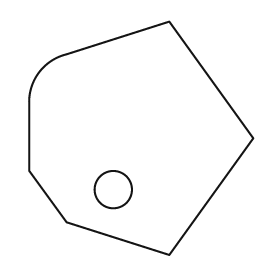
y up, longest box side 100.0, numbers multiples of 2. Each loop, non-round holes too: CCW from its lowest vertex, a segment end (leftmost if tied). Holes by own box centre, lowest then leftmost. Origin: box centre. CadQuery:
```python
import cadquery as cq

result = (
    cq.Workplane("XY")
    .moveTo(12.0, -50.0)
    .lineTo(48.0, 0.0)
    .lineTo(12.0, 50.0)
    .lineTo(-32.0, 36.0)
    .threePointArc((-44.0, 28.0), (-48.0, 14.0))
    .lineTo(-48.0, -14.0)
    .lineTo(-32.0, -36.0)
    .close()
    .moveTo(-12.0, -22.0)
    .circle(8.0)
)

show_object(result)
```